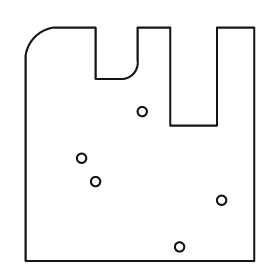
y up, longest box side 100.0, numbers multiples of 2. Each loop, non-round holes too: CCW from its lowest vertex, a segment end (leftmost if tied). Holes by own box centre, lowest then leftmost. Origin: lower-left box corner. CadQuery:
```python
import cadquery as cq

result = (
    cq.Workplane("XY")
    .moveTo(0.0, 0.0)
    .lineTo(98.0, 0.0)
    .lineTo(98.0, 100.0)
    .lineTo(82.0, 100.0)
    .lineTo(82.0, 58.0)
    .lineTo(62.0, 58.0)
    .lineTo(62.0, 100.0)
    .lineTo(48.0, 100.0)
    .lineTo(48.0, 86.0)
    .threePointArc((46.0, 80.0), (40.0, 78.0))
    .lineTo(30.0, 78.0)
    .lineTo(30.0, 100.0)
    .lineTo(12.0, 100.0)
    .threePointArc((4.0, 96.0), (0.0, 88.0))
    .close()
    .moveTo(66.0, 6.0)
    .circle(2.0)
    .moveTo(84.0, 26.0)
    .circle(2.0)
    .moveTo(30.0, 34.0)
    .circle(2.0)
    .moveTo(24.0, 44.0)
    .circle(2.0)
    .moveTo(50.0, 64.0)
    .circle(2.0)
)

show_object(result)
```